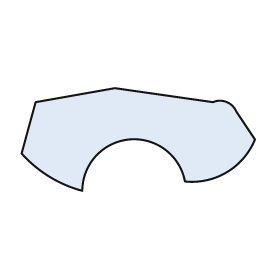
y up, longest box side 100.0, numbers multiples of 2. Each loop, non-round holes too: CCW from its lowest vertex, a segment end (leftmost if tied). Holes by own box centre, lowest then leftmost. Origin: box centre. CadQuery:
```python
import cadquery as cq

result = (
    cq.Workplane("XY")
    .moveTo(-24.0, -22.0)
    .threePointArc((-4.0, 0.0), (20.0, -18.0))
    .threePointArc((38.0, -14.0), (50.0, 0.0))
    .lineTo(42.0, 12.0)
    .threePointArc((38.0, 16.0), (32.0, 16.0))
    .lineTo(-10.0, 22.0)
    .lineTo(-44.0, 16.0)
    .lineTo(-50.0, -6.0)
    .threePointArc((-38.0, -16.0), (-24.0, -22.0))
    .close()
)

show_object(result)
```